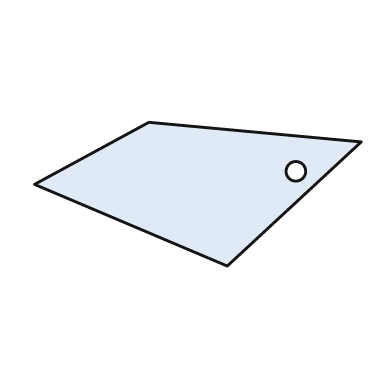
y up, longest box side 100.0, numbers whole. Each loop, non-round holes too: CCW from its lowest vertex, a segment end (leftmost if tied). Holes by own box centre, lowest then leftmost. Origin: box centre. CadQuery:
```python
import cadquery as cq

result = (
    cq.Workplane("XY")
    .moveTo(9.0, -22.0)
    .lineTo(50.0, 16.0)
    .lineTo(-15.0, 22.0)
    .lineTo(-50.0, 3.0)
    .close()
    .moveTo(30.0, 7.0)
    .circle(3.0)
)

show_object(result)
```